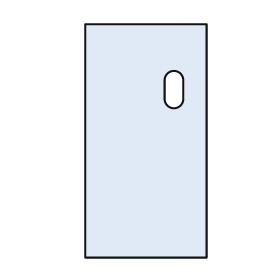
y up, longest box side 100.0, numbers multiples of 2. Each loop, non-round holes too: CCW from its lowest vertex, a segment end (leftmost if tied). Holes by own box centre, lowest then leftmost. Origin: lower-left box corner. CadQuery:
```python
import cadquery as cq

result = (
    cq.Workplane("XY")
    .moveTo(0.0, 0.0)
    .lineTo(52.0, 0.0)
    .lineTo(52.0, 100.0)
    .lineTo(0.0, 100.0)
    .close()
    .moveTo(34.0, 68.0)
    .threePointArc((38.0, 64.0), (42.0, 68.0))
    .lineTo(42.0, 76.0)
    .threePointArc((38.0, 80.0), (34.0, 76.0))
    .close()
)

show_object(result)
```